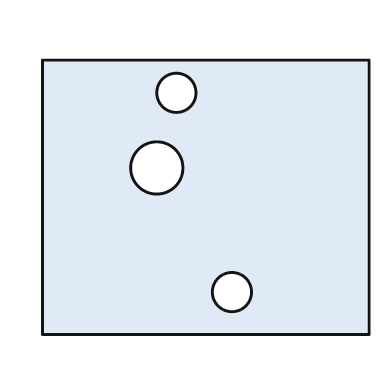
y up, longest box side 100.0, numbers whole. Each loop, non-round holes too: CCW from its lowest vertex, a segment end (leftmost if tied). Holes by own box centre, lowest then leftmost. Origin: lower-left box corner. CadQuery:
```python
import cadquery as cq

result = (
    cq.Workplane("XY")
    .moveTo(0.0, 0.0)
    .lineTo(100.0, 0.0)
    .lineTo(100.0, 84.0)
    .lineTo(0.0, 84.0)
    .close()
    .moveTo(58.0, 13.0)
    .circle(6.0)
    .moveTo(35.0, 51.0)
    .circle(8.0)
    .moveTo(41.0, 74.0)
    .circle(6.0)
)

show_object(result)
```